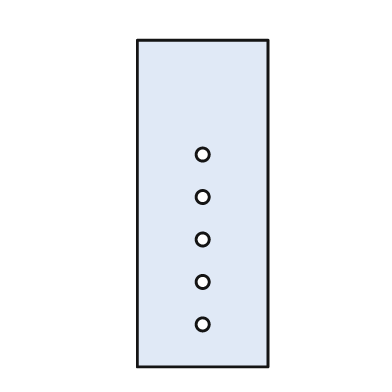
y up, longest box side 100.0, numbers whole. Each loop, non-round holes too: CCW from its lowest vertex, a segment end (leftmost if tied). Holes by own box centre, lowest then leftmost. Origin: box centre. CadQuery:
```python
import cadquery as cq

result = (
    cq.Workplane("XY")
    .moveTo(-20.0, -50.0)
    .lineTo(20.0, -50.0)
    .lineTo(20.0, 50.0)
    .lineTo(-20.0, 50.0)
    .close()
    .moveTo(0.0, -37.0)
    .circle(2.0)
    .moveTo(0.0, -24.0)
    .circle(2.0)
    .moveTo(0.0, -11.0)
    .circle(2.0)
    .moveTo(0.0, 2.0)
    .circle(2.0)
    .moveTo(0.0, 15.0)
    .circle(2.0)
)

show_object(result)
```